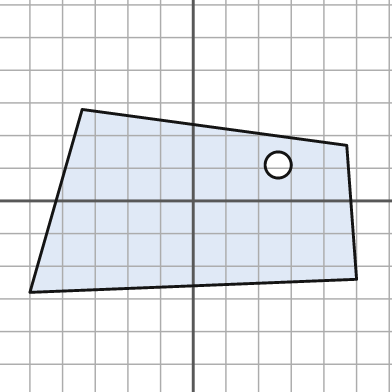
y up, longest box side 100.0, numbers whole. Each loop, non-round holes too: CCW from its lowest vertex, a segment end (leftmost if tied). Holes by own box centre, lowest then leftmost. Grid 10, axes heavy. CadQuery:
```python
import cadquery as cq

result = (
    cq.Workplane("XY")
    .moveTo(-50.0, -28.0)
    .lineTo(50.0, -24.0)
    .lineTo(47.0, 17.0)
    .lineTo(-34.0, 28.0)
    .close()
    .moveTo(26.0, 11.0)
    .circle(4.0)
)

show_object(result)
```